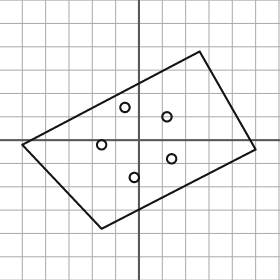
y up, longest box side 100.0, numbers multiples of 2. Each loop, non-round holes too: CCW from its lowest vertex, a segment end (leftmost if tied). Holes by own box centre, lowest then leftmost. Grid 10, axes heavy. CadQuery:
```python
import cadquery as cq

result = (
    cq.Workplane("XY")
    .moveTo(-16.0, -38.0)
    .lineTo(50.0, -4.0)
    .lineTo(26.0, 38.0)
    .lineTo(-50.0, -2.0)
    .close()
    .moveTo(-2.0, -16.0)
    .circle(2.0)
    .moveTo(14.0, -8.0)
    .circle(2.0)
    .moveTo(-16.0, -2.0)
    .circle(2.0)
    .moveTo(12.0, 10.0)
    .circle(2.0)
    .moveTo(-6.0, 14.0)
    .circle(2.0)
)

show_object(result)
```